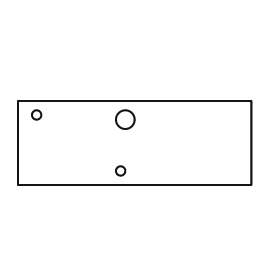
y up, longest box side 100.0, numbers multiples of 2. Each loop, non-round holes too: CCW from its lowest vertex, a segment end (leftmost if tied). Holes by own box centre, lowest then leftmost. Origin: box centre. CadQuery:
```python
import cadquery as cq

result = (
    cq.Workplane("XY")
    .moveTo(-50.0, -18.0)
    .lineTo(50.0, -18.0)
    .lineTo(50.0, 18.0)
    .lineTo(-50.0, 18.0)
    .close()
    .moveTo(-6.0, -12.0)
    .circle(2.0)
    .moveTo(-4.0, 10.0)
    .circle(4.0)
    .moveTo(-42.0, 12.0)
    .circle(2.0)
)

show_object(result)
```